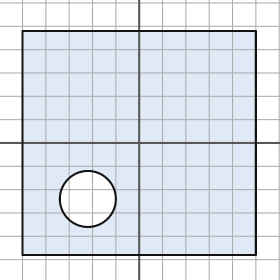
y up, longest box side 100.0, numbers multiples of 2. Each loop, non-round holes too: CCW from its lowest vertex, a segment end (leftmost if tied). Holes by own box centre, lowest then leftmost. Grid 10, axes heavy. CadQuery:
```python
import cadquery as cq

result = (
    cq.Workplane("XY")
    .moveTo(-50.0, -48.0)
    .lineTo(50.0, -48.0)
    .lineTo(50.0, 48.0)
    .lineTo(-50.0, 48.0)
    .close()
    .moveTo(-22.0, -24.0)
    .circle(12.0)
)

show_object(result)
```